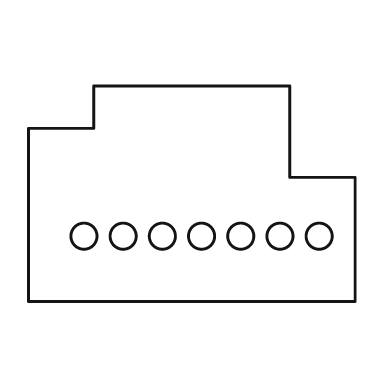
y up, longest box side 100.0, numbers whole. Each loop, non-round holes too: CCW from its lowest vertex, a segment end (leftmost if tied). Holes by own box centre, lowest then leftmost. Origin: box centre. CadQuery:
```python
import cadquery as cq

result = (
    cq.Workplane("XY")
    .moveTo(-50.0, -33.0)
    .lineTo(50.0, -33.0)
    .lineTo(50.0, 5.0)
    .lineTo(30.0, 5.0)
    .lineTo(30.0, 33.0)
    .lineTo(-30.0, 33.0)
    .lineTo(-30.0, 20.0)
    .lineTo(-50.0, 20.0)
    .close()
    .moveTo(-33.0, -13.0)
    .circle(4.0)
    .moveTo(-21.0, -13.0)
    .circle(4.0)
    .moveTo(-9.0, -13.0)
    .circle(4.0)
    .moveTo(3.0, -13.0)
    .circle(4.0)
    .moveTo(15.0, -13.0)
    .circle(4.0)
    .moveTo(27.0, -13.0)
    .circle(4.0)
    .moveTo(39.0, -13.0)
    .circle(4.0)
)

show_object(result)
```